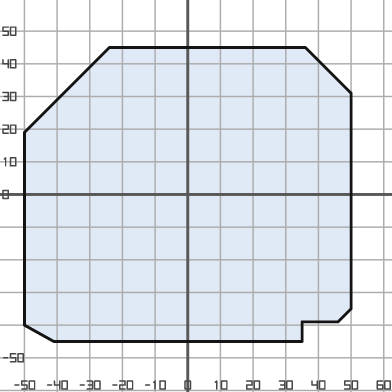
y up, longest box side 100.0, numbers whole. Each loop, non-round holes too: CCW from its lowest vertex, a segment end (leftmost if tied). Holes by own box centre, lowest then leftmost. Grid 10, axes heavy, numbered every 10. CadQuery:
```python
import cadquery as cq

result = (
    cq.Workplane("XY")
    .moveTo(-41.0, -45.0)
    .lineTo(35.0, -45.0)
    .lineTo(35.0, -39.0)
    .lineTo(46.0, -39.0)
    .lineTo(50.0, -35.0)
    .lineTo(50.0, 31.0)
    .lineTo(36.0, 45.0)
    .lineTo(-24.0, 45.0)
    .lineTo(-50.0, 19.0)
    .lineTo(-50.0, -40.0)
    .close()
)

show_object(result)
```